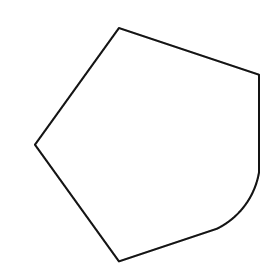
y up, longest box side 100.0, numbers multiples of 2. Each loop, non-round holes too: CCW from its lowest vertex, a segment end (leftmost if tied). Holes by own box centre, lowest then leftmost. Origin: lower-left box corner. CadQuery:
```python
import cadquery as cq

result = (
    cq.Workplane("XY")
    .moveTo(36.0, 0.0)
    .lineTo(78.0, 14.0)
    .threePointArc((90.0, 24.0), (96.0, 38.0))
    .lineTo(96.0, 80.0)
    .lineTo(36.0, 100.0)
    .lineTo(0.0, 50.0)
    .close()
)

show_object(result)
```